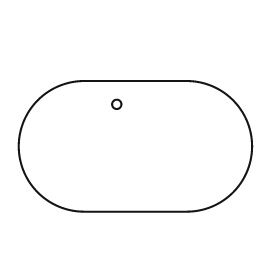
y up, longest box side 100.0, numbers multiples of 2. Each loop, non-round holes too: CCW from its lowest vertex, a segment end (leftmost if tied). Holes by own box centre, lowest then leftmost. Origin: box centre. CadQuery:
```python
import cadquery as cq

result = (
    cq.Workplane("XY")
    .moveTo(-22.0, -28.0)
    .lineTo(22.0, -28.0)
    .threePointArc((50.0, 0.0), (22.0, 28.0))
    .lineTo(-22.0, 28.0)
    .threePointArc((-50.0, 0.0), (-22.0, -28.0))
    .close()
    .moveTo(-8.0, 18.0)
    .circle(2.0)
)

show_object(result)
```